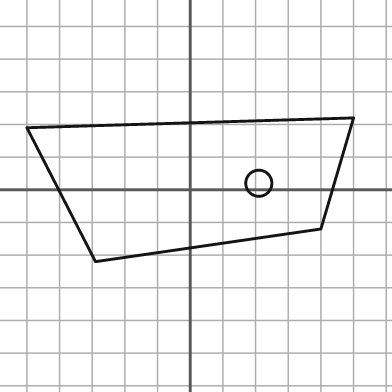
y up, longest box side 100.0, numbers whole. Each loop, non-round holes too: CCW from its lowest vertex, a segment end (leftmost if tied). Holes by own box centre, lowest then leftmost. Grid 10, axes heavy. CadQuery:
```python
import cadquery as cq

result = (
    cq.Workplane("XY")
    .moveTo(-29.0, -22.0)
    .lineTo(40.0, -12.0)
    .lineTo(50.0, 22.0)
    .lineTo(-50.0, 19.0)
    .close()
    .moveTo(21.0, 2.0)
    .circle(4.0)
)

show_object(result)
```